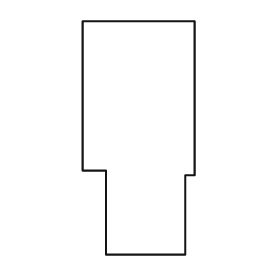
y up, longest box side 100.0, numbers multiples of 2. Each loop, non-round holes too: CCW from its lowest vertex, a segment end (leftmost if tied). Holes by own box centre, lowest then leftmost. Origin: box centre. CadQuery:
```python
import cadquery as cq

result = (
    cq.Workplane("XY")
    .moveTo(-14.0, -50.0)
    .lineTo(20.0, -50.0)
    .lineTo(20.0, -16.0)
    .lineTo(24.0, -16.0)
    .lineTo(24.0, 50.0)
    .lineTo(-24.0, 50.0)
    .lineTo(-24.0, -14.0)
    .lineTo(-14.0, -14.0)
    .close()
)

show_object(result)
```